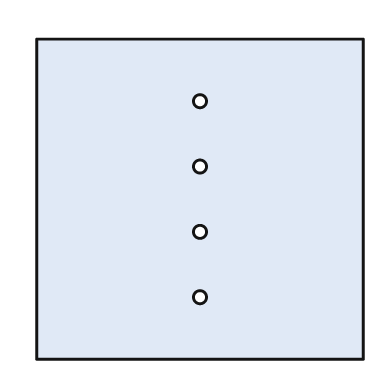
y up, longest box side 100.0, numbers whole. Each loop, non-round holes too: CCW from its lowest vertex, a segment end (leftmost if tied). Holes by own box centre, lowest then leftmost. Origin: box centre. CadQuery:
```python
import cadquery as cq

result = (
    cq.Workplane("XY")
    .moveTo(-50.0, -49.0)
    .lineTo(50.0, -49.0)
    .lineTo(50.0, 49.0)
    .lineTo(-50.0, 49.0)
    .close()
    .moveTo(0.0, -30.0)
    .circle(2.0)
    .moveTo(0.0, -10.0)
    .circle(2.0)
    .moveTo(0.0, 10.0)
    .circle(2.0)
    .moveTo(0.0, 30.0)
    .circle(2.0)
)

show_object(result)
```